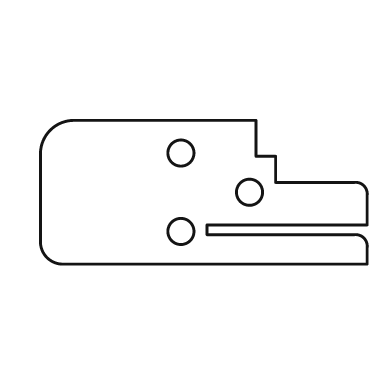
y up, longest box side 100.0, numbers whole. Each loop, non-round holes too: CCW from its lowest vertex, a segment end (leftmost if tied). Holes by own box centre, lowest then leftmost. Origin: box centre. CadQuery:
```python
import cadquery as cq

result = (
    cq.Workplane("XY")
    .moveTo(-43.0, -22.0)
    .lineTo(50.0, -22.0)
    .lineTo(50.0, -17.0)
    .threePointArc((49.0, -14.0), (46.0, -13.0))
    .lineTo(1.0, -13.0)
    .lineTo(1.0, -10.0)
    .lineTo(50.0, -10.0)
    .lineTo(50.0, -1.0)
    .threePointArc((49.0, 2.0), (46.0, 3.0))
    .lineTo(22.0, 3.0)
    .lineTo(22.0, 11.0)
    .lineTo(16.0, 11.0)
    .lineTo(16.0, 22.0)
    .lineTo(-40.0, 22.0)
    .threePointArc((-47.0, 19.0), (-50.0, 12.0))
    .lineTo(-50.0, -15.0)
    .threePointArc((-48.0, -20.0), (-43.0, -22.0))
    .close()
    .moveTo(-7.0, -12.0)
    .circle(4.0)
    .moveTo(14.0, 0.0)
    .circle(4.0)
    .moveTo(-7.0, 12.0)
    .circle(4.0)
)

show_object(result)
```